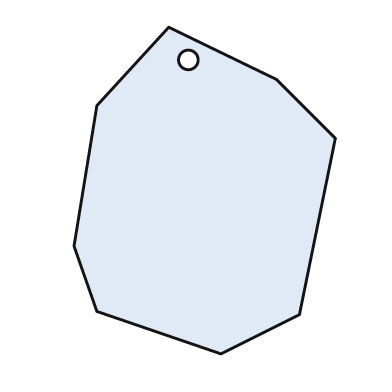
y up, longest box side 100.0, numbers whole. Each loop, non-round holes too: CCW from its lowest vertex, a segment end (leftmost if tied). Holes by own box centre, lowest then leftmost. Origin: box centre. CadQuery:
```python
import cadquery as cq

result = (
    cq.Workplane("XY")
    .moveTo(5.0, -50.0)
    .lineTo(29.0, -38.0)
    .lineTo(40.0, 16.0)
    .lineTo(22.0, 34.0)
    .lineTo(-11.0, 50.0)
    .lineTo(-33.0, 26.0)
    .lineTo(-40.0, -17.0)
    .lineTo(-33.0, -37.0)
    .close()
    .moveTo(-5.0, 40.0)
    .circle(3.0)
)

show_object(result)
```